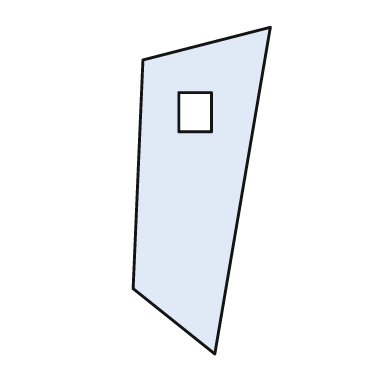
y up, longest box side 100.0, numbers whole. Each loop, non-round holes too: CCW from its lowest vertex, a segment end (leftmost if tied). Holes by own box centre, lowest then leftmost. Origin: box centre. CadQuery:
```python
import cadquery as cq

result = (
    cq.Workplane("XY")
    .moveTo(4.0, -50.0)
    .lineTo(21.0, 50.0)
    .lineTo(-18.0, 40.0)
    .lineTo(-21.0, -30.0)
    .close()
    .moveTo(-7.0, 18.0)
    .lineTo(3.0, 18.0)
    .lineTo(3.0, 30.0)
    .lineTo(-7.0, 30.0)
    .close()
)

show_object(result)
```